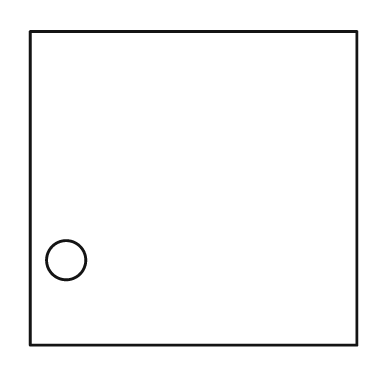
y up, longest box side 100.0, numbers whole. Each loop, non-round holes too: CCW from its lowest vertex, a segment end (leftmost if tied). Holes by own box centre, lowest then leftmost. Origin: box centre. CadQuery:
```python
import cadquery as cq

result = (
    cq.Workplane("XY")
    .moveTo(-50.0, -48.0)
    .lineTo(50.0, -48.0)
    .lineTo(50.0, 48.0)
    .lineTo(-50.0, 48.0)
    .close()
    .moveTo(-39.0, -22.0)
    .circle(6.0)
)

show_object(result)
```